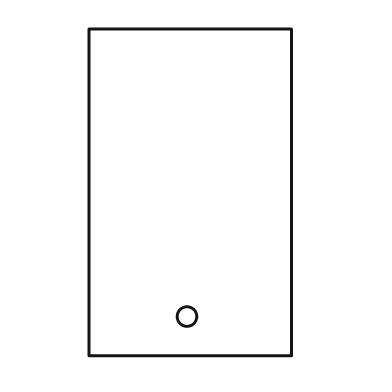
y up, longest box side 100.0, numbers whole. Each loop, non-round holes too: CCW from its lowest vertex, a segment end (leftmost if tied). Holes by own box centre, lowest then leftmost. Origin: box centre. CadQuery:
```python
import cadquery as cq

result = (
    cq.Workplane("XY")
    .moveTo(-31.0, -50.0)
    .lineTo(31.0, -50.0)
    .lineTo(31.0, 50.0)
    .lineTo(-31.0, 50.0)
    .close()
    .moveTo(-1.0, -38.0)
    .circle(3.0)
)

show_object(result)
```